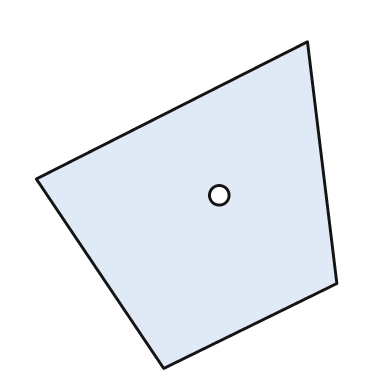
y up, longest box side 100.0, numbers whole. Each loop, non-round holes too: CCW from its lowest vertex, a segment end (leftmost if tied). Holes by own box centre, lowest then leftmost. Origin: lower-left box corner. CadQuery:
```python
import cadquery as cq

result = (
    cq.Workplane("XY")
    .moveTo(39.0, 0.0)
    .lineTo(92.0, 26.0)
    .lineTo(83.0, 100.0)
    .lineTo(0.0, 58.0)
    .close()
    .moveTo(56.0, 53.0)
    .circle(3.0)
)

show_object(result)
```